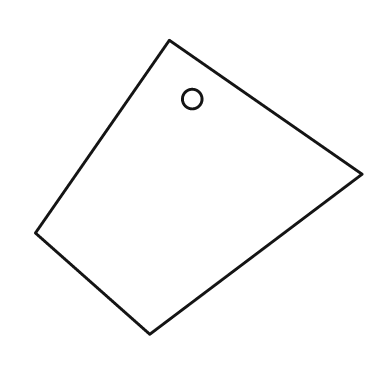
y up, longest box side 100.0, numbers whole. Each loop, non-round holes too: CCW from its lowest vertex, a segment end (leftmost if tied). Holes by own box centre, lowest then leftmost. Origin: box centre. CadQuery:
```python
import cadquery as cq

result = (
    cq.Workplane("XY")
    .moveTo(-15.0, -45.0)
    .lineTo(50.0, 4.0)
    .lineTo(-9.0, 45.0)
    .lineTo(-50.0, -14.0)
    .close()
    .moveTo(-2.0, 27.0)
    .circle(3.0)
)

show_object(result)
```